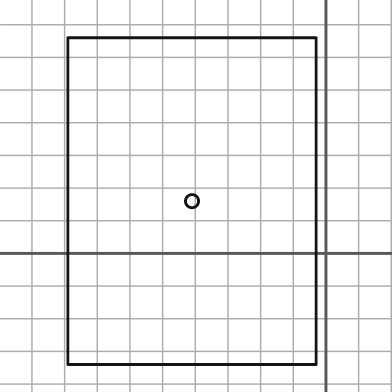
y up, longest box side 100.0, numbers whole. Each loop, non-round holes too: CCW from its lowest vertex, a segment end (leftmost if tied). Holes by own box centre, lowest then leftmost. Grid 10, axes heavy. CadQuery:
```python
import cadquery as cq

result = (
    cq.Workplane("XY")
    .moveTo(-79.0, -34.0)
    .lineTo(-3.0, -34.0)
    .lineTo(-3.0, 66.0)
    .lineTo(-79.0, 66.0)
    .close()
    .moveTo(-41.0, 16.0)
    .circle(2.0)
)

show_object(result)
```